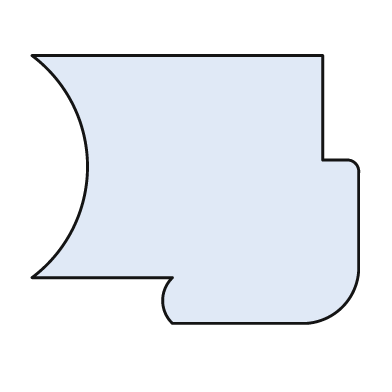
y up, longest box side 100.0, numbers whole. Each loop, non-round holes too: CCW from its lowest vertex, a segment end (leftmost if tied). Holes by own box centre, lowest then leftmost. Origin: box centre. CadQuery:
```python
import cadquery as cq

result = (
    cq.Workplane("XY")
    .moveTo(-7.0, -41.0)
    .lineTo(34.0, -41.0)
    .threePointArc((45.0, -36.0), (50.0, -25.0))
    .lineTo(50.0, 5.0)
    .threePointArc((49.0, 8.0), (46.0, 9.0))
    .lineTo(39.0, 9.0)
    .lineTo(39.0, 41.0)
    .lineTo(-50.0, 41.0)
    .threePointArc((-33.0, 7.0), (-50.0, -27.0))
    .lineTo(-7.0, -27.0)
    .threePointArc((-10.0, -34.0), (-7.0, -41.0))
    .close()
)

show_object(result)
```